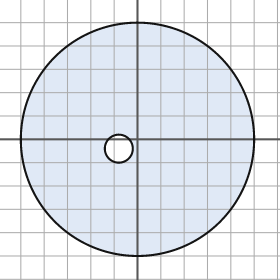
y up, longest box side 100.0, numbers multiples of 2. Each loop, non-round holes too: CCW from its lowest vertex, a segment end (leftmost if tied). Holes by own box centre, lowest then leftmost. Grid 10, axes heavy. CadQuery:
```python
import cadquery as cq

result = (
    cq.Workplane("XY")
    .moveTo(0.0, 0.0)
    .circle(50.0)
    .moveTo(-8.0, -4.0)
    .circle(6.0)
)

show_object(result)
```